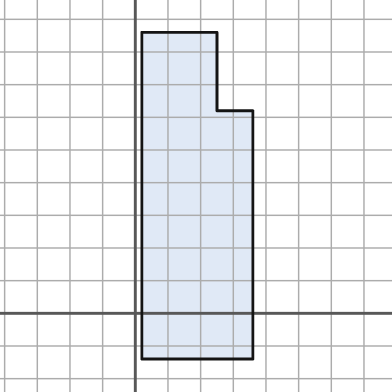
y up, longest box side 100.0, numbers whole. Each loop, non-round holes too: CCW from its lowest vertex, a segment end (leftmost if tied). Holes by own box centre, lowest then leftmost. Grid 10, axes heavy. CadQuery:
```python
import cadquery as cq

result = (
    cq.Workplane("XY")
    .moveTo(2.0, -14.0)
    .lineTo(36.0, -14.0)
    .lineTo(36.0, 62.0)
    .lineTo(25.0, 62.0)
    .lineTo(25.0, 86.0)
    .lineTo(2.0, 86.0)
    .close()
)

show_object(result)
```